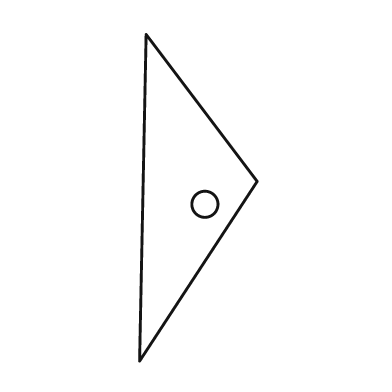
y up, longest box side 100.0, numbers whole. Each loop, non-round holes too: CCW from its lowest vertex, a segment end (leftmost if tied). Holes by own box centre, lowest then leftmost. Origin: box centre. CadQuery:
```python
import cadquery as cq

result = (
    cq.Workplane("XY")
    .moveTo(-18.0, -50.0)
    .lineTo(18.0, 5.0)
    .lineTo(-16.0, 50.0)
    .close()
    .moveTo(2.0, -2.0)
    .circle(4.0)
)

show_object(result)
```